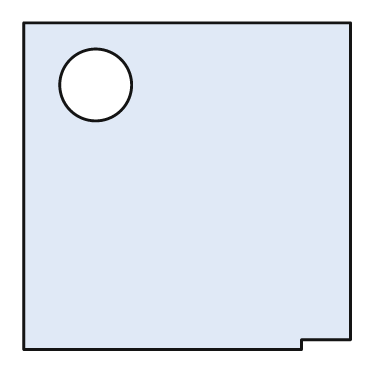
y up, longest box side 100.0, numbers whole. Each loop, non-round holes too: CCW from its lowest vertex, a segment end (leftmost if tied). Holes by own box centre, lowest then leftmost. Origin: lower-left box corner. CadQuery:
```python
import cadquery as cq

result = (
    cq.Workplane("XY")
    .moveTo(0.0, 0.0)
    .lineTo(85.0, 0.0)
    .lineTo(85.0, 3.0)
    .lineTo(100.0, 3.0)
    .lineTo(100.0, 100.0)
    .lineTo(0.0, 100.0)
    .close()
    .moveTo(22.0, 81.0)
    .circle(11.0)
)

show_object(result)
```